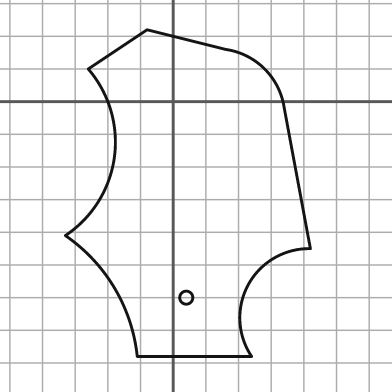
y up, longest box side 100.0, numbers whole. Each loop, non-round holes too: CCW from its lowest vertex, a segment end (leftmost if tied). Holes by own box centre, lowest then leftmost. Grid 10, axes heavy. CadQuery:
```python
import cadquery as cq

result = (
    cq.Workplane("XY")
    .moveTo(-11.0, -78.0)
    .lineTo(24.0, -78.0)
    .threePointArc((23.0, -56.0), (42.0, -45.0))
    .lineTo(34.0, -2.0)
    .threePointArc((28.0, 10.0), (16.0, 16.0))
    .lineTo(-8.0, 22.0)
    .lineTo(-26.0, 10.0)
    .threePointArc((-18.0, -17.0), (-33.0, -41.0))
    .threePointArc((-18.0, -57.0), (-11.0, -78.0))
    .close()
    .moveTo(4.0, -60.0)
    .circle(2.0)
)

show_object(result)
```